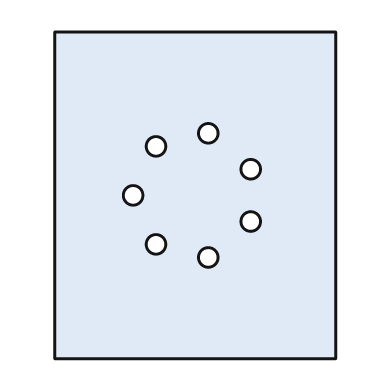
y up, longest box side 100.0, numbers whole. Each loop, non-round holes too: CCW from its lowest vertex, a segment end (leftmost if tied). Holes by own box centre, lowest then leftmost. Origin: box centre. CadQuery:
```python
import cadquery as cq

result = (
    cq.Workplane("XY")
    .moveTo(-43.0, -50.0)
    .lineTo(43.0, -50.0)
    .lineTo(43.0, 50.0)
    .lineTo(-43.0, 50.0)
    .close()
    .moveTo(4.0, -19.0)
    .circle(3.0)
    .moveTo(-12.0, -15.0)
    .circle(3.0)
    .moveTo(17.0, -8.0)
    .circle(3.0)
    .moveTo(-19.0, 0.0)
    .circle(3.0)
    .moveTo(17.0, 8.0)
    .circle(3.0)
    .moveTo(-12.0, 15.0)
    .circle(3.0)
    .moveTo(4.0, 19.0)
    .circle(3.0)
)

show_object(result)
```